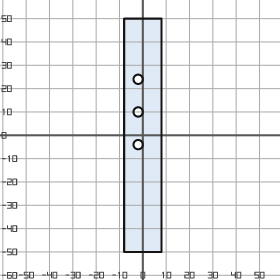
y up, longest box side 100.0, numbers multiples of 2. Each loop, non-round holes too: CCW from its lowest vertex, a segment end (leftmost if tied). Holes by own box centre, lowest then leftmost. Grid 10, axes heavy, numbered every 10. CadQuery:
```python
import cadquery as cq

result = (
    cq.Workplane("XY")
    .moveTo(-8.0, -50.0)
    .lineTo(8.0, -50.0)
    .lineTo(8.0, 50.0)
    .lineTo(-8.0, 50.0)
    .close()
    .moveTo(-2.0, -4.0)
    .circle(2.0)
    .moveTo(-2.0, 10.0)
    .circle(2.0)
    .moveTo(-2.0, 24.0)
    .circle(2.0)
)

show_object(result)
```